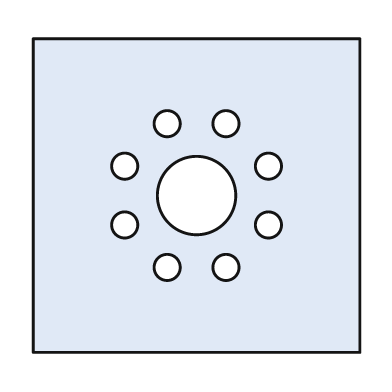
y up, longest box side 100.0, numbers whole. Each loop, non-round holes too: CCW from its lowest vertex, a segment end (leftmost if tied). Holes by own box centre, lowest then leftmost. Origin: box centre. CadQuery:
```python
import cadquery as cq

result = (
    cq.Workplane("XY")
    .moveTo(-50.0, -48.0)
    .lineTo(50.0, -48.0)
    .lineTo(50.0, 48.0)
    .lineTo(-50.0, 48.0)
    .close()
    .moveTo(-9.0, -22.0)
    .circle(4.0)
    .moveTo(9.0, -22.0)
    .circle(4.0)
    .moveTo(-22.0, -9.0)
    .circle(4.0)
    .moveTo(22.0, -9.0)
    .circle(4.0)
    .moveTo(0.0, 0.0)
    .circle(12.0)
    .moveTo(-22.0, 9.0)
    .circle(4.0)
    .moveTo(22.0, 9.0)
    .circle(4.0)
    .moveTo(-9.0, 22.0)
    .circle(4.0)
    .moveTo(9.0, 22.0)
    .circle(4.0)
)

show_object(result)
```